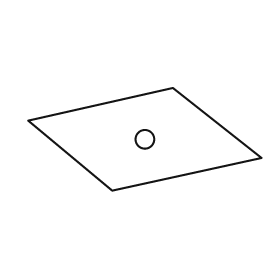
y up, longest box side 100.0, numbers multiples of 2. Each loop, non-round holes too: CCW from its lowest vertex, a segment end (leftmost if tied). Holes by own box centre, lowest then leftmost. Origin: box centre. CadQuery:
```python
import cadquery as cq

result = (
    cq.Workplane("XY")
    .moveTo(-14.0, -22.0)
    .lineTo(50.0, -8.0)
    .lineTo(12.0, 22.0)
    .lineTo(-50.0, 8.0)
    .close()
    .moveTo(0.0, 0.0)
    .circle(4.0)
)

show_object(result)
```